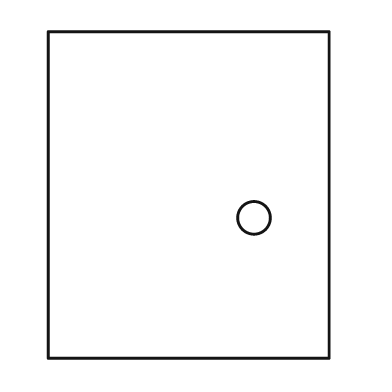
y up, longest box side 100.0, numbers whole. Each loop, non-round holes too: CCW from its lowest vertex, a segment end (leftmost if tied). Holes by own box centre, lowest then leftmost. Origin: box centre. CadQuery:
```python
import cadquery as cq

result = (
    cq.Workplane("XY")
    .moveTo(-43.0, -50.0)
    .lineTo(43.0, -50.0)
    .lineTo(43.0, 50.0)
    .lineTo(-43.0, 50.0)
    .close()
    .moveTo(20.0, -7.0)
    .circle(5.0)
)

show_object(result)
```